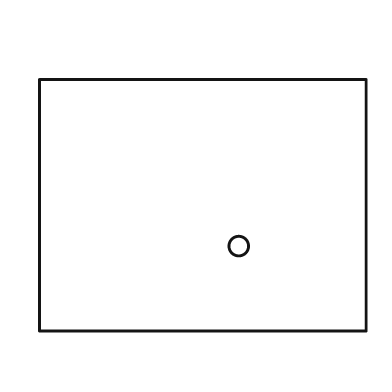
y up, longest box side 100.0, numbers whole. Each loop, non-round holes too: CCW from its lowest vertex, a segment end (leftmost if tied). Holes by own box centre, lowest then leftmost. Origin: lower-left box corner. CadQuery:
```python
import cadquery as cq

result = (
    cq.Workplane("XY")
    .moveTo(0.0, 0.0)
    .lineTo(100.0, 0.0)
    .lineTo(100.0, 77.0)
    .lineTo(0.0, 77.0)
    .close()
    .moveTo(61.0, 26.0)
    .circle(3.0)
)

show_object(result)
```